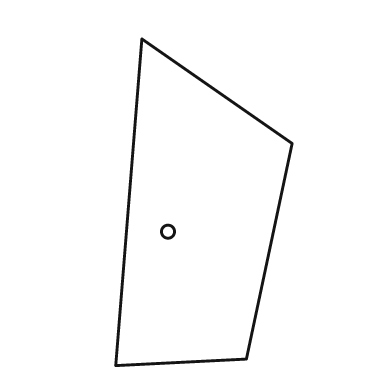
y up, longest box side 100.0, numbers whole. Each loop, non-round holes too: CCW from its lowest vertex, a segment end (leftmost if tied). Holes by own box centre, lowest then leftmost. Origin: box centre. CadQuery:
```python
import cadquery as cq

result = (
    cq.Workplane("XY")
    .moveTo(-27.0, -50.0)
    .lineTo(13.0, -48.0)
    .lineTo(27.0, 18.0)
    .lineTo(-19.0, 50.0)
    .close()
    .moveTo(-11.0, -9.0)
    .circle(2.0)
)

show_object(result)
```